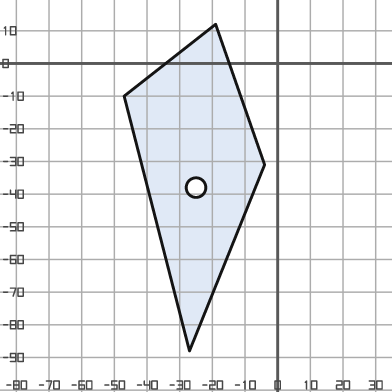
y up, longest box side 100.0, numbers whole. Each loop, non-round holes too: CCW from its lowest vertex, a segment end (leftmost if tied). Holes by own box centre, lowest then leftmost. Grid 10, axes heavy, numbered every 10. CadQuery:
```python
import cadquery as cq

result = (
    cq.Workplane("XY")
    .moveTo(-27.0, -88.0)
    .lineTo(-4.0, -31.0)
    .lineTo(-19.0, 12.0)
    .lineTo(-47.0, -10.0)
    .close()
    .moveTo(-25.0, -38.0)
    .circle(3.0)
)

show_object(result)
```